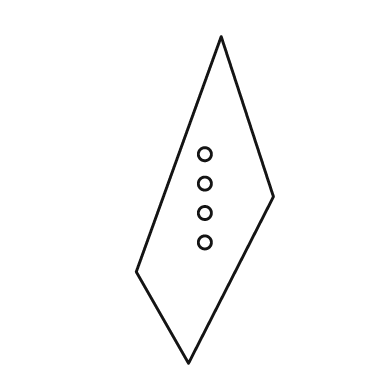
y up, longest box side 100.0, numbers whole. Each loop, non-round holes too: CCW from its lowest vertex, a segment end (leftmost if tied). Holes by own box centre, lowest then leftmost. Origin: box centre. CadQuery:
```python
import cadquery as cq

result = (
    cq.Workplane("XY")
    .moveTo(-5.0, -50.0)
    .lineTo(21.0, 1.0)
    .lineTo(5.0, 50.0)
    .lineTo(-21.0, -22.0)
    .close()
    .moveTo(0.0, -13.0)
    .circle(2.0)
    .moveTo(0.0, -4.0)
    .circle(2.0)
    .moveTo(0.0, 5.0)
    .circle(2.0)
    .moveTo(0.0, 14.0)
    .circle(2.0)
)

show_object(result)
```